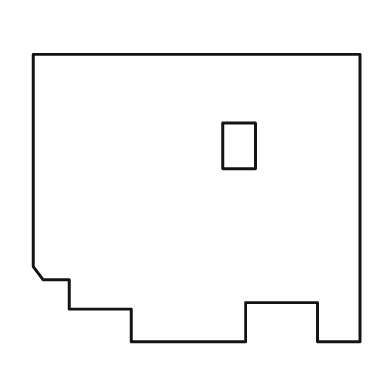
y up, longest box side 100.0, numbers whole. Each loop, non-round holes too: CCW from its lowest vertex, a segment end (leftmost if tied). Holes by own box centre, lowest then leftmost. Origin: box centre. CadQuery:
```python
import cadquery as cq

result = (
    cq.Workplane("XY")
    .moveTo(-20.0, -44.0)
    .lineTo(15.0, -44.0)
    .lineTo(15.0, -32.0)
    .lineTo(37.0, -32.0)
    .lineTo(37.0, -44.0)
    .lineTo(50.0, -44.0)
    .lineTo(50.0, 44.0)
    .lineTo(-50.0, 44.0)
    .lineTo(-50.0, -21.0)
    .lineTo(-47.0, -25.0)
    .lineTo(-39.0, -25.0)
    .lineTo(-39.0, -34.0)
    .lineTo(-20.0, -34.0)
    .close()
    .moveTo(8.0, 9.0)
    .lineTo(18.0, 9.0)
    .lineTo(18.0, 23.0)
    .lineTo(8.0, 23.0)
    .close()
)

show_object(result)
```